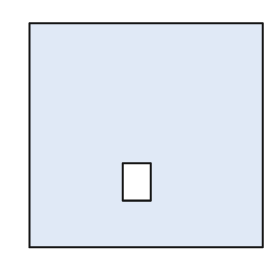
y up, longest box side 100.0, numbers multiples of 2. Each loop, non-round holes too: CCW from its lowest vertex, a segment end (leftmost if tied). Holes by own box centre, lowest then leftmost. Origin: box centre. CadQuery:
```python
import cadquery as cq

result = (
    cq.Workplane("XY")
    .moveTo(-50.0, -48.0)
    .lineTo(50.0, -48.0)
    .lineTo(50.0, 48.0)
    .lineTo(-50.0, 48.0)
    .close()
    .moveTo(-10.0, -28.0)
    .lineTo(2.0, -28.0)
    .lineTo(2.0, -12.0)
    .lineTo(-10.0, -12.0)
    .close()
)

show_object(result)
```